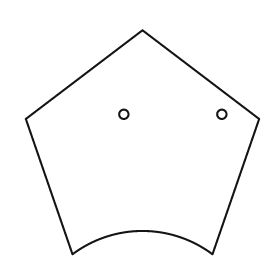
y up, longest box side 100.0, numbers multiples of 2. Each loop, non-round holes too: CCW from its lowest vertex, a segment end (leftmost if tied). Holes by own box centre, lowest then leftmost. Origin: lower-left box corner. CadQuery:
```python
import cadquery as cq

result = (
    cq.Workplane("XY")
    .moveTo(20.0, 0.0)
    .threePointArc((50.0, 10.0), (80.0, 0.0))
    .lineTo(100.0, 58.0)
    .lineTo(50.0, 96.0)
    .lineTo(0.0, 58.0)
    .close()
    .moveTo(42.0, 60.0)
    .circle(2.0)
    .moveTo(84.0, 60.0)
    .circle(2.0)
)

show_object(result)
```